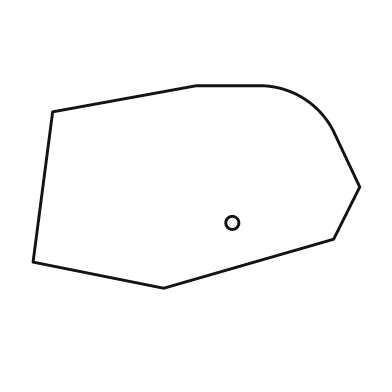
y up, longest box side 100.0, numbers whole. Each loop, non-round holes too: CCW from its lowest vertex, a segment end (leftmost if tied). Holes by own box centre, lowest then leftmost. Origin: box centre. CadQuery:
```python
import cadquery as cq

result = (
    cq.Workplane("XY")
    .moveTo(-10.0, -31.0)
    .lineTo(42.0, -16.0)
    .lineTo(50.0, 0.0)
    .lineTo(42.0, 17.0)
    .threePointArc((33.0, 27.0), (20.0, 31.0))
    .lineTo(0.0, 31.0)
    .lineTo(-44.0, 23.0)
    .lineTo(-50.0, -23.0)
    .close()
    .moveTo(11.0, -11.0)
    .circle(2.0)
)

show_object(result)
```